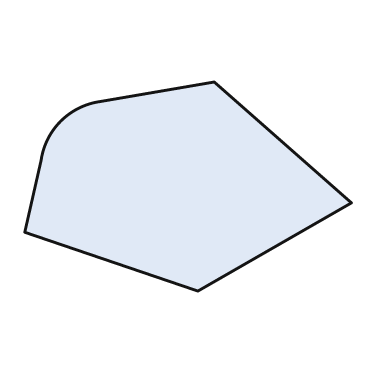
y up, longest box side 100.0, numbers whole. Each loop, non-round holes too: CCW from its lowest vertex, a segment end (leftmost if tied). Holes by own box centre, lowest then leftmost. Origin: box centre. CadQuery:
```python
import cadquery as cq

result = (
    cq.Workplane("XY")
    .moveTo(3.0, -32.0)
    .lineTo(50.0, -5.0)
    .lineTo(8.0, 32.0)
    .lineTo(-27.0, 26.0)
    .threePointArc((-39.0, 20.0), (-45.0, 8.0))
    .lineTo(-50.0, -14.0)
    .close()
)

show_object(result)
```